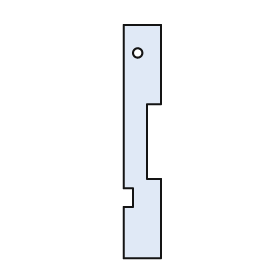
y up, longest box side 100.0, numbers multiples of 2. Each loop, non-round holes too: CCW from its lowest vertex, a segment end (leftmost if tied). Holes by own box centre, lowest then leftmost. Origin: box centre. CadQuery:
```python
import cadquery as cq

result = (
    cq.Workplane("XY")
    .moveTo(-8.0, -50.0)
    .lineTo(8.0, -50.0)
    .lineTo(8.0, -16.0)
    .lineTo(2.0, -16.0)
    .lineTo(2.0, 16.0)
    .lineTo(8.0, 16.0)
    .lineTo(8.0, 50.0)
    .lineTo(-8.0, 50.0)
    .lineTo(-8.0, -20.0)
    .lineTo(-4.0, -20.0)
    .lineTo(-4.0, -28.0)
    .lineTo(-8.0, -28.0)
    .close()
    .moveTo(-2.0, 38.0)
    .circle(2.0)
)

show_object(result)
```